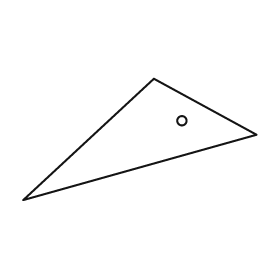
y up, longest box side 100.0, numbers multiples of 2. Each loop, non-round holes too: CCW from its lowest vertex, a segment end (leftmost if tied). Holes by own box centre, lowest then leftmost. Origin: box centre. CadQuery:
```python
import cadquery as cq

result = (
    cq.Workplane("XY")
    .moveTo(-50.0, -26.0)
    .lineTo(50.0, 2.0)
    .lineTo(6.0, 26.0)
    .close()
    .moveTo(18.0, 8.0)
    .circle(2.0)
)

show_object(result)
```